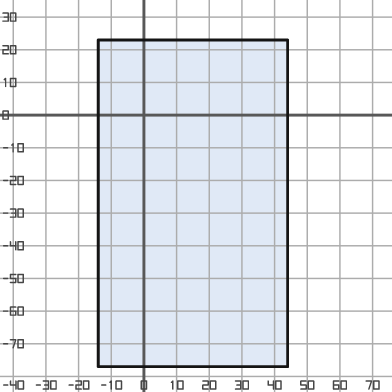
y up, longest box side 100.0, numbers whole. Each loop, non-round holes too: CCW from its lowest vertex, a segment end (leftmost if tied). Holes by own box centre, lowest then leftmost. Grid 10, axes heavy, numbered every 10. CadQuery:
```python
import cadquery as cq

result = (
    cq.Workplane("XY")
    .moveTo(-14.0, -77.0)
    .lineTo(44.0, -77.0)
    .lineTo(44.0, 23.0)
    .lineTo(-14.0, 23.0)
    .close()
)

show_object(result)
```